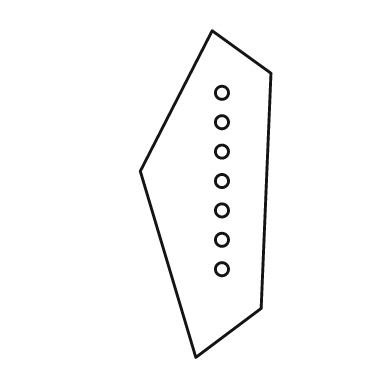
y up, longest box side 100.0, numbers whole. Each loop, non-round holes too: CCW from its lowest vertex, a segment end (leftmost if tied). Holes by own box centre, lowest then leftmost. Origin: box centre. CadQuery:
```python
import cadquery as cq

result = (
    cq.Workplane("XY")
    .moveTo(-3.0, -50.0)
    .lineTo(17.0, -35.0)
    .lineTo(20.0, 37.0)
    .lineTo(2.0, 50.0)
    .lineTo(-20.0, 7.0)
    .close()
    .moveTo(5.0, -23.0)
    .circle(2.0)
    .moveTo(5.0, -14.0)
    .circle(2.0)
    .moveTo(5.0, -5.0)
    .circle(2.0)
    .moveTo(5.0, 4.0)
    .circle(2.0)
    .moveTo(5.0, 13.0)
    .circle(2.0)
    .moveTo(5.0, 22.0)
    .circle(2.0)
    .moveTo(5.0, 31.0)
    .circle(2.0)
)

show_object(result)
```